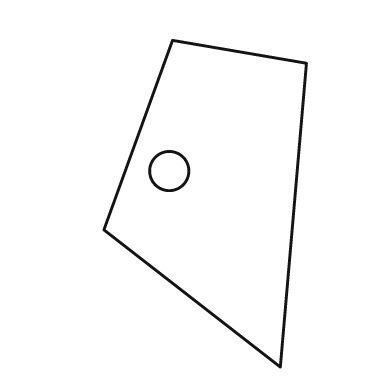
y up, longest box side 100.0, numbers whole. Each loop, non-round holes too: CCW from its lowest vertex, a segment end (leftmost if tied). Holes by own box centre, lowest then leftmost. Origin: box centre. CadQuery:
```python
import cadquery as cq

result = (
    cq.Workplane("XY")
    .moveTo(23.0, -50.0)
    .lineTo(31.0, 43.0)
    .lineTo(-10.0, 50.0)
    .lineTo(-31.0, -8.0)
    .close()
    .moveTo(-11.0, 10.0)
    .circle(6.0)
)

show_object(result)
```